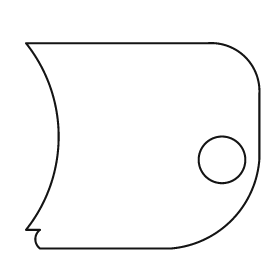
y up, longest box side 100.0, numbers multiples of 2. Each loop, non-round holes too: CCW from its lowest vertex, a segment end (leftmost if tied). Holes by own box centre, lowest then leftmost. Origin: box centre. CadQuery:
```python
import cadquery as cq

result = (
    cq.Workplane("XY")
    .moveTo(-44.0, -44.0)
    .lineTo(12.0, -44.0)
    .threePointArc((38.0, -32.0), (50.0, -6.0))
    .lineTo(50.0, 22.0)
    .threePointArc((44.0, 38.0), (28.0, 44.0))
    .lineTo(-50.0, 44.0)
    .threePointArc((-36.0, 4.0), (-50.0, -36.0))
    .lineTo(-44.0, -36.0)
    .threePointArc((-46.0, -40.0), (-44.0, -44.0))
    .close()
    .moveTo(34.0, -6.0)
    .circle(10.0)
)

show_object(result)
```